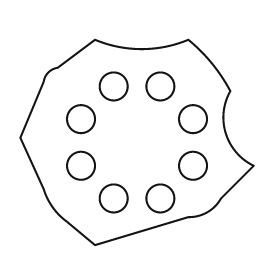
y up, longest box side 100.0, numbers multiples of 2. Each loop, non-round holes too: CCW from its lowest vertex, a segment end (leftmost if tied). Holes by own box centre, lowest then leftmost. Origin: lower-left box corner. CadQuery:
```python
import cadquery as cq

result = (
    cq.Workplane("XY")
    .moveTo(32.0, 0.0)
    .lineTo(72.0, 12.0)
    .threePointArc((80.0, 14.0), (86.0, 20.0))
    .lineTo(100.0, 34.0)
    .threePointArc((88.0, 48.0), (90.0, 66.0))
    .threePointArc((82.0, 78.0), (72.0, 88.0))
    .threePointArc((52.0, 84.0), (32.0, 88.0))
    .lineTo(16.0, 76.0)
    .threePointArc((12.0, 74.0), (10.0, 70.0))
    .lineTo(0.0, 46.0)
    .lineTo(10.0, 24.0)
    .threePointArc((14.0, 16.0), (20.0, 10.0))
    .close()
    .moveTo(40.0, 20.0)
    .circle(6.0)
    .moveTo(60.0, 20.0)
    .circle(6.0)
    .moveTo(26.0, 34.0)
    .circle(6.0)
    .moveTo(74.0, 34.0)
    .circle(6.0)
    .moveTo(26.0, 54.0)
    .circle(6.0)
    .moveTo(74.0, 54.0)
    .circle(6.0)
    .moveTo(40.0, 68.0)
    .circle(6.0)
    .moveTo(60.0, 68.0)
    .circle(6.0)
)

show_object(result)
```